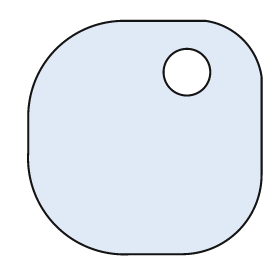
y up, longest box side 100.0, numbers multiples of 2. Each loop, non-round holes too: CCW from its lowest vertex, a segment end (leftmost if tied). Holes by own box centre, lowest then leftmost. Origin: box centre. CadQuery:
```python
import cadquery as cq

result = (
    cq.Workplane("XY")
    .moveTo(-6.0, -50.0)
    .lineTo(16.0, -50.0)
    .threePointArc((40.0, -40.0), (50.0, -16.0))
    .lineTo(50.0, 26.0)
    .threePointArc((42.0, 42.0), (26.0, 50.0))
    .lineTo(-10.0, 50.0)
    .threePointArc((-38.0, 38.0), (-50.0, 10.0))
    .lineTo(-50.0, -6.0)
    .threePointArc((-38.0, -38.0), (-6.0, -50.0))
    .close()
    .moveTo(18.0, 28.0)
    .circle(10.0)
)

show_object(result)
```